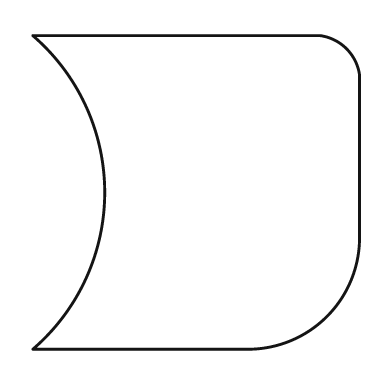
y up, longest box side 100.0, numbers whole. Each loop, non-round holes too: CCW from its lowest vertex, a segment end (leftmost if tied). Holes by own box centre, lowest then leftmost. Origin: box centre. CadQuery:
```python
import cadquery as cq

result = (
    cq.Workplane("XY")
    .moveTo(-50.0, -48.0)
    .lineTo(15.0, -48.0)
    .threePointArc((40.0, -38.0), (50.0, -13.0))
    .lineTo(50.0, 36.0)
    .threePointArc((46.0, 44.0), (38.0, 48.0))
    .lineTo(-50.0, 48.0)
    .threePointArc((-28.0, 0.0), (-50.0, -48.0))
    .close()
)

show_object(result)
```